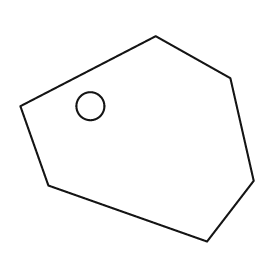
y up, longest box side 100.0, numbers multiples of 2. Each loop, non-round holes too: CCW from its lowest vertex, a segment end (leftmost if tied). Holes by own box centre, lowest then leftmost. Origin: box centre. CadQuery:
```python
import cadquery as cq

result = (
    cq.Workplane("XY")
    .moveTo(30.0, -44.0)
    .lineTo(50.0, -18.0)
    .lineTo(40.0, 26.0)
    .lineTo(8.0, 44.0)
    .lineTo(-50.0, 14.0)
    .lineTo(-38.0, -20.0)
    .close()
    .moveTo(-20.0, 14.0)
    .circle(6.0)
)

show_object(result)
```